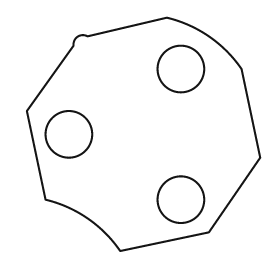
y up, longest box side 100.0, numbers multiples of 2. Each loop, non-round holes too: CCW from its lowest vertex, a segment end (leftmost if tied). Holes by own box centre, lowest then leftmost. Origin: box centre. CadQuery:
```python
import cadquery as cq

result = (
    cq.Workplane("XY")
    .moveTo(-10.0, -50.0)
    .lineTo(28.0, -42.0)
    .lineTo(50.0, -10.0)
    .lineTo(42.0, 28.0)
    .threePointArc((28.0, 42.0), (10.0, 50.0))
    .lineTo(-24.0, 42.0)
    .threePointArc((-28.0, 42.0), (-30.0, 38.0))
    .lineTo(-50.0, 10.0)
    .lineTo(-42.0, -28.0)
    .threePointArc((-24.0, -36.0), (-10.0, -50.0))
    .close()
    .moveTo(16.0, -28.0)
    .circle(10.0)
    .moveTo(-32.0, 0.0)
    .circle(10.0)
    .moveTo(16.0, 28.0)
    .circle(10.0)
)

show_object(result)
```